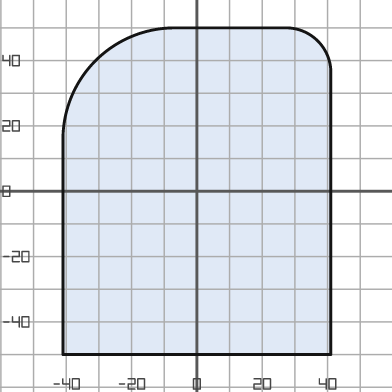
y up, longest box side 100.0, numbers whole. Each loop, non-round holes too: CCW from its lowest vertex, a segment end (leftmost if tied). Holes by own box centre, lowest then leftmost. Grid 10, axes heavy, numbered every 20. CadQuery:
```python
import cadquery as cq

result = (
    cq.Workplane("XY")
    .moveTo(-41.0, -50.0)
    .lineTo(41.0, -50.0)
    .lineTo(41.0, 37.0)
    .threePointArc((37.0, 46.0), (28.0, 50.0))
    .lineTo(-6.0, 50.0)
    .threePointArc((-31.0, 40.0), (-41.0, 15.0))
    .close()
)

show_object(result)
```